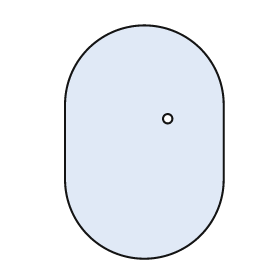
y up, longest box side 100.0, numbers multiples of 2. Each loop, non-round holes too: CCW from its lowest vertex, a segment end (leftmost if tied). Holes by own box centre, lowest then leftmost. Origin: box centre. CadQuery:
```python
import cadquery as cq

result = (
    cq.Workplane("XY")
    .moveTo(-34.0, -16.0)
    .threePointArc((0.0, -50.0), (34.0, -16.0))
    .lineTo(34.0, 16.0)
    .threePointArc((0.0, 50.0), (-34.0, 16.0))
    .close()
    .moveTo(10.0, 10.0)
    .circle(2.0)
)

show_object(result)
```